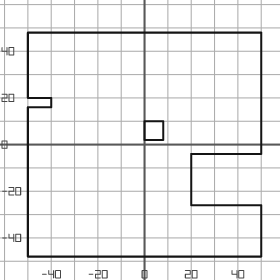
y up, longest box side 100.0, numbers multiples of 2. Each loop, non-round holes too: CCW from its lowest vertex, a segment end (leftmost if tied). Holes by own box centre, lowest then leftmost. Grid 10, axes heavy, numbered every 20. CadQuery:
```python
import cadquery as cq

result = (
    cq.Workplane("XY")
    .moveTo(-50.0, -48.0)
    .lineTo(50.0, -48.0)
    .lineTo(50.0, -26.0)
    .lineTo(20.0, -26.0)
    .lineTo(20.0, -4.0)
    .lineTo(50.0, -4.0)
    .lineTo(50.0, 48.0)
    .lineTo(-50.0, 48.0)
    .lineTo(-50.0, 20.0)
    .lineTo(-40.0, 20.0)
    .lineTo(-40.0, 16.0)
    .lineTo(-50.0, 16.0)
    .close()
    .moveTo(0.0, 2.0)
    .lineTo(8.0, 2.0)
    .lineTo(8.0, 10.0)
    .lineTo(0.0, 10.0)
    .close()
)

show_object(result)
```